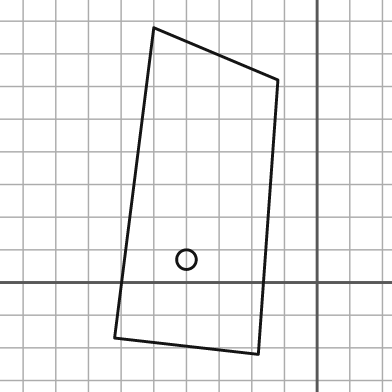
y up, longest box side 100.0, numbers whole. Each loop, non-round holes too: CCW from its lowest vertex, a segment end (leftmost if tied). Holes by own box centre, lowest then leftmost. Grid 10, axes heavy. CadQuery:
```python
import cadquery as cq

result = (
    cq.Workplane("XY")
    .moveTo(-18.0, -22.0)
    .lineTo(-12.0, 62.0)
    .lineTo(-50.0, 78.0)
    .lineTo(-62.0, -17.0)
    .close()
    .moveTo(-40.0, 7.0)
    .circle(3.0)
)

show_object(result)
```